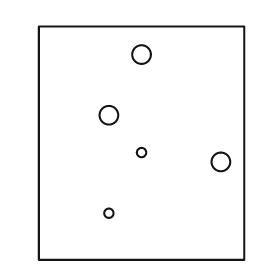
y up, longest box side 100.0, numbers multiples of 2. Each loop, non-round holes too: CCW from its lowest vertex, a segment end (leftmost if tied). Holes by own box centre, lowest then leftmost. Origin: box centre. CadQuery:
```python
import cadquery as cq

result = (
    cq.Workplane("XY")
    .moveTo(-44.0, -50.0)
    .lineTo(44.0, -50.0)
    .lineTo(44.0, 50.0)
    .lineTo(-44.0, 50.0)
    .close()
    .moveTo(-14.0, -30.0)
    .circle(2.0)
    .moveTo(34.0, -8.0)
    .circle(4.0)
    .moveTo(0.0, -4.0)
    .circle(2.0)
    .moveTo(-14.0, 12.0)
    .circle(4.0)
    .moveTo(0.0, 38.0)
    .circle(4.0)
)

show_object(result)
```